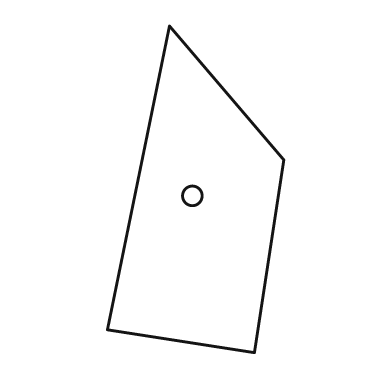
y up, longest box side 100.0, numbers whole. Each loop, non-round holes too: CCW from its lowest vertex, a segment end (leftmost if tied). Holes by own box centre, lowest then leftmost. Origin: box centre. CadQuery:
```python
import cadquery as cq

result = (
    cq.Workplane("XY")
    .moveTo(18.0, -50.0)
    .lineTo(27.0, 9.0)
    .lineTo(-8.0, 50.0)
    .lineTo(-27.0, -43.0)
    .close()
    .moveTo(-1.0, -2.0)
    .circle(3.0)
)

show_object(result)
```